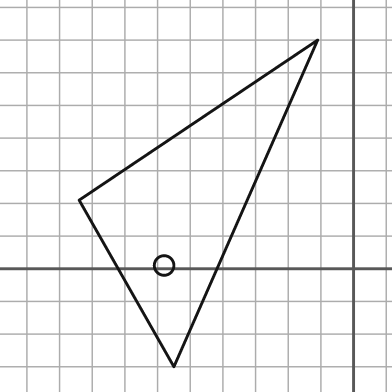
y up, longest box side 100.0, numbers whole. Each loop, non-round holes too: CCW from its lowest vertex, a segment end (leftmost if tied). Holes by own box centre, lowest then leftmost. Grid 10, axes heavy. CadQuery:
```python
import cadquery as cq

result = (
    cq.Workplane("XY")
    .moveTo(-55.0, -30.0)
    .lineTo(-11.0, 70.0)
    .lineTo(-84.0, 21.0)
    .close()
    .moveTo(-58.0, 1.0)
    .circle(3.0)
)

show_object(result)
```